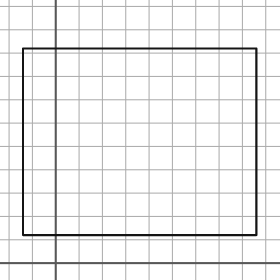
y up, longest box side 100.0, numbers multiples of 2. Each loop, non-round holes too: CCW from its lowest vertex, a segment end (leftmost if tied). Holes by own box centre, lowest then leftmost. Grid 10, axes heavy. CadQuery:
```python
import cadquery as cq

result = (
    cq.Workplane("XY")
    .moveTo(-14.0, 12.0)
    .lineTo(86.0, 12.0)
    .lineTo(86.0, 92.0)
    .lineTo(-14.0, 92.0)
    .close()
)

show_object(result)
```